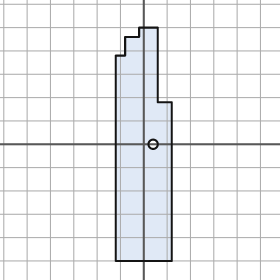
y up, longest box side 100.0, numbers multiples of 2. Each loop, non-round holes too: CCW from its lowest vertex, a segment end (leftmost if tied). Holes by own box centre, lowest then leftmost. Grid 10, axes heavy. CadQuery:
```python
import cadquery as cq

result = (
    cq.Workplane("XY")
    .moveTo(-12.0, -50.0)
    .lineTo(12.0, -50.0)
    .lineTo(12.0, 18.0)
    .lineTo(6.0, 18.0)
    .lineTo(6.0, 50.0)
    .lineTo(-2.0, 50.0)
    .lineTo(-2.0, 46.0)
    .lineTo(-8.0, 46.0)
    .lineTo(-8.0, 38.0)
    .lineTo(-12.0, 38.0)
    .close()
    .moveTo(4.0, 0.0)
    .circle(2.0)
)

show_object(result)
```